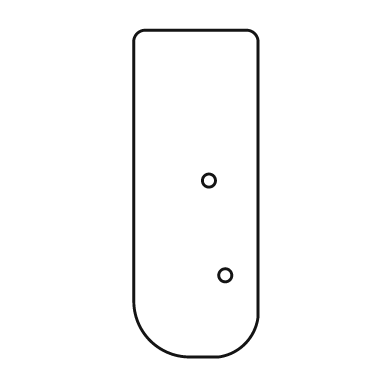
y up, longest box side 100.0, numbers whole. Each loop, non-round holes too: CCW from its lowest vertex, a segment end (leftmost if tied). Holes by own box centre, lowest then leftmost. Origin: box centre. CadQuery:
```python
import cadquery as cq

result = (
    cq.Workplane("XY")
    .moveTo(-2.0, -50.0)
    .lineTo(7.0, -50.0)
    .threePointArc((15.0, -46.0), (19.0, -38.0))
    .lineTo(19.0, 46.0)
    .threePointArc((18.0, 49.0), (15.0, 50.0))
    .lineTo(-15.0, 50.0)
    .threePointArc((-18.0, 49.0), (-19.0, 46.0))
    .lineTo(-19.0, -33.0)
    .threePointArc((-14.0, -45.0), (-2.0, -50.0))
    .close()
    .moveTo(9.0, -25.0)
    .circle(2.0)
    .moveTo(4.0, 4.0)
    .circle(2.0)
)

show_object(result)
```